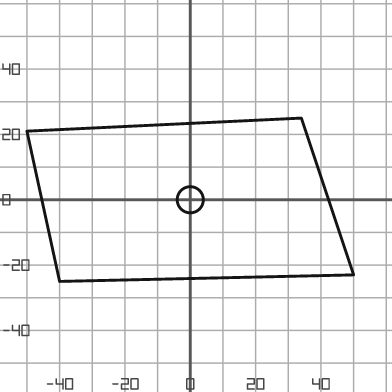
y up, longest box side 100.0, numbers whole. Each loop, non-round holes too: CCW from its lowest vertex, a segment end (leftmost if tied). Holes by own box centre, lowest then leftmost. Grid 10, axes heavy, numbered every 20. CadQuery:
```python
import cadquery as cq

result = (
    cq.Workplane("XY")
    .moveTo(-40.0, -25.0)
    .lineTo(50.0, -23.0)
    .lineTo(34.0, 25.0)
    .lineTo(-50.0, 21.0)
    .close()
    .moveTo(0.0, 0.0)
    .circle(4.0)
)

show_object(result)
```